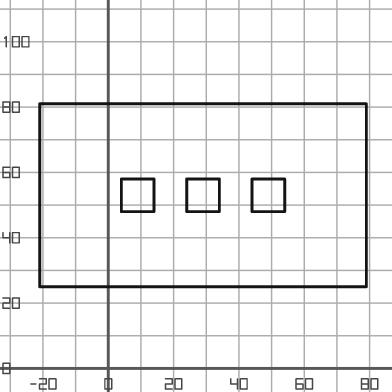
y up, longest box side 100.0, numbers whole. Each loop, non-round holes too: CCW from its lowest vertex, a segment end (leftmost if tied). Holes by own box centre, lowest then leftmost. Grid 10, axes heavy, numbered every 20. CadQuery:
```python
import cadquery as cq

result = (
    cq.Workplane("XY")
    .moveTo(-21.0, 25.0)
    .lineTo(79.0, 25.0)
    .lineTo(79.0, 81.0)
    .lineTo(-21.0, 81.0)
    .close()
    .moveTo(4.0, 48.0)
    .lineTo(14.0, 48.0)
    .lineTo(14.0, 58.0)
    .lineTo(4.0, 58.0)
    .close()
    .moveTo(24.0, 48.0)
    .lineTo(34.0, 48.0)
    .lineTo(34.0, 58.0)
    .lineTo(24.0, 58.0)
    .close()
    .moveTo(44.0, 48.0)
    .lineTo(54.0, 48.0)
    .lineTo(54.0, 58.0)
    .lineTo(44.0, 58.0)
    .close()
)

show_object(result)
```